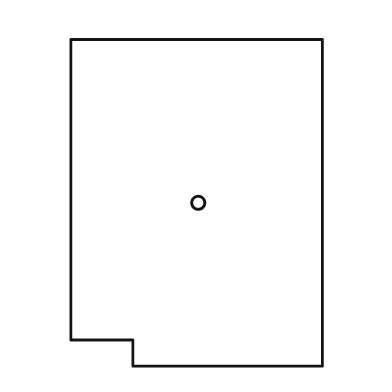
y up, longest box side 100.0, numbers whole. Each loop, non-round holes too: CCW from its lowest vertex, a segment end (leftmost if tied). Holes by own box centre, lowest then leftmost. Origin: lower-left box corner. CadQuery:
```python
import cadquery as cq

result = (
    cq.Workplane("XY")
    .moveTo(19.0, 0.0)
    .lineTo(77.0, 0.0)
    .lineTo(77.0, 100.0)
    .lineTo(0.0, 100.0)
    .lineTo(0.0, 8.0)
    .lineTo(19.0, 8.0)
    .close()
    .moveTo(39.0, 50.0)
    .circle(2.0)
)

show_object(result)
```